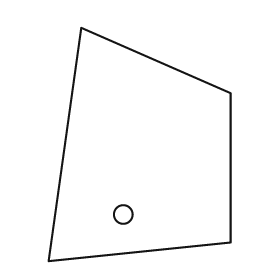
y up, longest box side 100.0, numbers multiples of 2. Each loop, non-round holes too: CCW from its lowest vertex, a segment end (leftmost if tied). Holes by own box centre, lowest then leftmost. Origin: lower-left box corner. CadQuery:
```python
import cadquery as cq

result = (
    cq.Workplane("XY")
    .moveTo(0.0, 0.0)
    .lineTo(78.0, 8.0)
    .lineTo(78.0, 72.0)
    .lineTo(14.0, 100.0)
    .close()
    .moveTo(32.0, 20.0)
    .circle(4.0)
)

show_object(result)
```